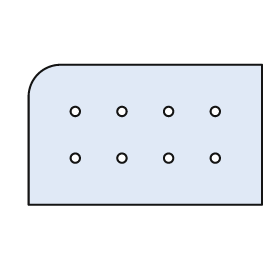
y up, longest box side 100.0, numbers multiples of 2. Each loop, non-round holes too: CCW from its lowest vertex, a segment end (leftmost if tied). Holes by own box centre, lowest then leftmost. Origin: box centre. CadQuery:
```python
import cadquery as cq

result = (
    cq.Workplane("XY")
    .moveTo(-50.0, -30.0)
    .lineTo(50.0, -30.0)
    .lineTo(50.0, 30.0)
    .lineTo(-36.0, 30.0)
    .threePointArc((-46.0, 26.0), (-50.0, 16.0))
    .close()
    .moveTo(-30.0, -10.0)
    .circle(2.0)
    .moveTo(-10.0, -10.0)
    .circle(2.0)
    .moveTo(10.0, -10.0)
    .circle(2.0)
    .moveTo(30.0, -10.0)
    .circle(2.0)
    .moveTo(-30.0, 10.0)
    .circle(2.0)
    .moveTo(-10.0, 10.0)
    .circle(2.0)
    .moveTo(10.0, 10.0)
    .circle(2.0)
    .moveTo(30.0, 10.0)
    .circle(2.0)
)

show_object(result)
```